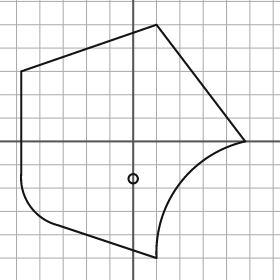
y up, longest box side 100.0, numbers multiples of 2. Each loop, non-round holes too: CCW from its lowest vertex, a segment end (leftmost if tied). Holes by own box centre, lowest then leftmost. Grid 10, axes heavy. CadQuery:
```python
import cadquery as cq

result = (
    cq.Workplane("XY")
    .moveTo(10.0, -50.0)
    .threePointArc((20.0, -18.0), (48.0, 0.0))
    .lineTo(10.0, 50.0)
    .lineTo(-48.0, 30.0)
    .lineTo(-48.0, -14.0)
    .threePointArc((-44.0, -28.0), (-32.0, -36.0))
    .close()
    .moveTo(0.0, -16.0)
    .circle(2.0)
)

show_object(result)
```